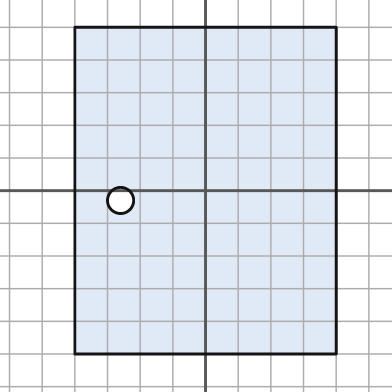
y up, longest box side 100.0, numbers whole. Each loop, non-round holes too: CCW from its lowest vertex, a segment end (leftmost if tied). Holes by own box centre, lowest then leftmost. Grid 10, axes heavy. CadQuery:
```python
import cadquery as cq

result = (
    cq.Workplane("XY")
    .moveTo(-40.0, -50.0)
    .lineTo(40.0, -50.0)
    .lineTo(40.0, 50.0)
    .lineTo(-40.0, 50.0)
    .close()
    .moveTo(-26.0, -3.0)
    .circle(4.0)
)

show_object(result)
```